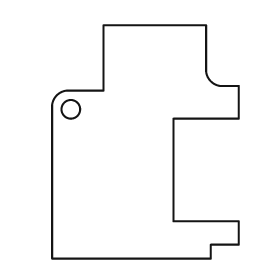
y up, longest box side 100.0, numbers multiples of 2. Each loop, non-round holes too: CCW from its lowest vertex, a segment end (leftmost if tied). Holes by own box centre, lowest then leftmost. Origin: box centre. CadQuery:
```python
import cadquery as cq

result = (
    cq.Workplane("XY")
    .moveTo(-40.0, -50.0)
    .lineTo(28.0, -50.0)
    .lineTo(28.0, -44.0)
    .lineTo(40.0, -44.0)
    .lineTo(40.0, -34.0)
    .lineTo(12.0, -34.0)
    .lineTo(12.0, 10.0)
    .lineTo(40.0, 10.0)
    .lineTo(40.0, 24.0)
    .lineTo(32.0, 24.0)
    .threePointArc((28.0, 26.0), (26.0, 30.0))
    .lineTo(26.0, 50.0)
    .lineTo(-18.0, 50.0)
    .lineTo(-18.0, 22.0)
    .lineTo(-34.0, 22.0)
    .threePointArc((-38.0, 20.0), (-40.0, 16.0))
    .close()
    .moveTo(-32.0, 14.0)
    .circle(4.0)
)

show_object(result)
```